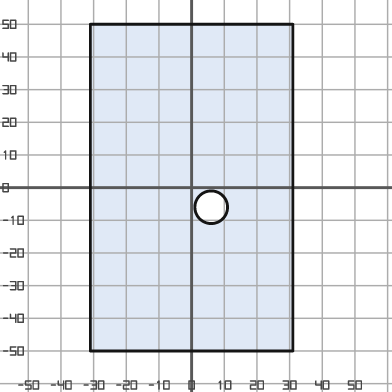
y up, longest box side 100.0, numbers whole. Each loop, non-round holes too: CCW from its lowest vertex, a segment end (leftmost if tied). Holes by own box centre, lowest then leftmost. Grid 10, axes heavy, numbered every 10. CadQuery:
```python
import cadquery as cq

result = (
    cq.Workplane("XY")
    .moveTo(-31.0, -50.0)
    .lineTo(31.0, -50.0)
    .lineTo(31.0, 50.0)
    .lineTo(-31.0, 50.0)
    .close()
    .moveTo(6.0, -6.0)
    .circle(5.0)
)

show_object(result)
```